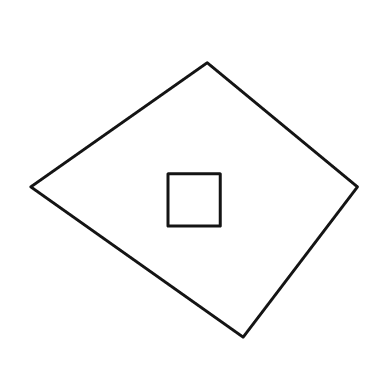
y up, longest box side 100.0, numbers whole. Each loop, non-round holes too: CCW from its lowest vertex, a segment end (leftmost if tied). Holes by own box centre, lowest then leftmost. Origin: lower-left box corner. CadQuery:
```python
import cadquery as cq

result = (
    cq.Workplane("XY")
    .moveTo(65.0, 0.0)
    .lineTo(100.0, 46.0)
    .lineTo(54.0, 84.0)
    .lineTo(0.0, 46.0)
    .close()
    .moveTo(42.0, 34.0)
    .lineTo(58.0, 34.0)
    .lineTo(58.0, 50.0)
    .lineTo(42.0, 50.0)
    .close()
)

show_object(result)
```